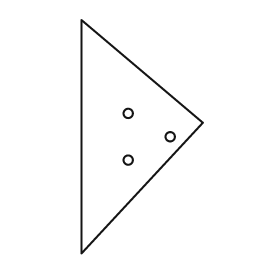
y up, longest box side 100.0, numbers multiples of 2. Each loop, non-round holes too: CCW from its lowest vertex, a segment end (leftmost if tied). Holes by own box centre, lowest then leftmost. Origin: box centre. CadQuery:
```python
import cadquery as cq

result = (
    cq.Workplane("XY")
    .moveTo(-26.0, -50.0)
    .lineTo(26.0, 6.0)
    .lineTo(-26.0, 50.0)
    .close()
    .moveTo(-6.0, -10.0)
    .circle(2.0)
    .moveTo(12.0, 0.0)
    .circle(2.0)
    .moveTo(-6.0, 10.0)
    .circle(2.0)
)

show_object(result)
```